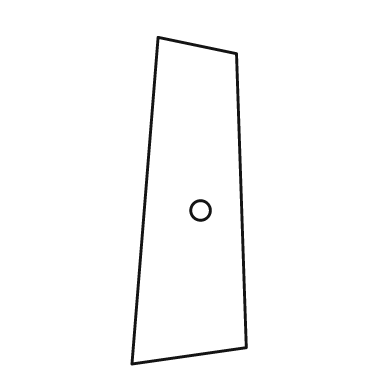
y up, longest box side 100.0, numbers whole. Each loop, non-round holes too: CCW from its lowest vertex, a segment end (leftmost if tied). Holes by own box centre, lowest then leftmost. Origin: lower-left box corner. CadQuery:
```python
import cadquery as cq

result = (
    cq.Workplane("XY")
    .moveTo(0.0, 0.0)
    .lineTo(35.0, 5.0)
    .lineTo(32.0, 95.0)
    .lineTo(8.0, 100.0)
    .close()
    .moveTo(21.0, 47.0)
    .circle(3.0)
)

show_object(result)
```